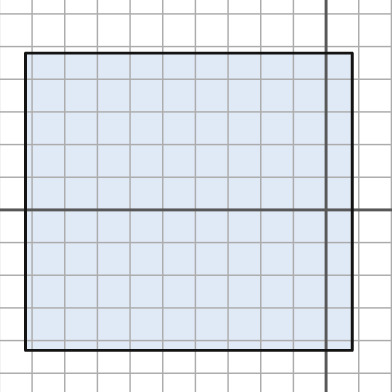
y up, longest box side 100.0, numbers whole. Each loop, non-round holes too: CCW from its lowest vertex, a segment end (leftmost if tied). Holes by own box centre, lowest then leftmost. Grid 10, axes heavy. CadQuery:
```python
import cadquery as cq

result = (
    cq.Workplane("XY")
    .moveTo(-92.0, -43.0)
    .lineTo(8.0, -43.0)
    .lineTo(8.0, 48.0)
    .lineTo(-92.0, 48.0)
    .close()
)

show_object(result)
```